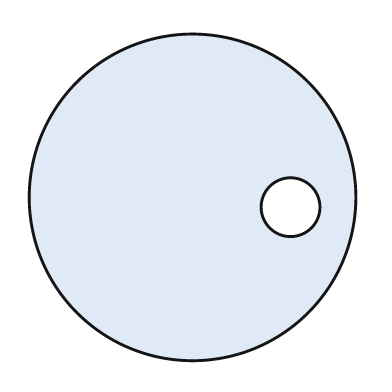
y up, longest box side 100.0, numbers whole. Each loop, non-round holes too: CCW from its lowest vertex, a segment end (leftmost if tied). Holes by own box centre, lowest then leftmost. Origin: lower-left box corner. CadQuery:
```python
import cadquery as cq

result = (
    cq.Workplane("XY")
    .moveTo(50.0, 50.0)
    .circle(50.0)
    .moveTo(80.0, 47.0)
    .circle(9.0)
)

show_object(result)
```